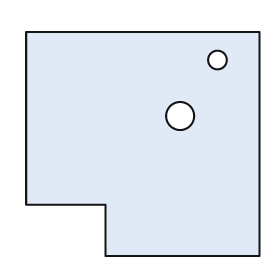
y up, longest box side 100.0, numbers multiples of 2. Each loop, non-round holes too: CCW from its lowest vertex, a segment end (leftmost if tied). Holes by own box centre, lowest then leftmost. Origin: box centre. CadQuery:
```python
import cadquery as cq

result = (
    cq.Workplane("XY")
    .moveTo(-16.0, -48.0)
    .lineTo(50.0, -48.0)
    .lineTo(50.0, 48.0)
    .lineTo(-50.0, 48.0)
    .lineTo(-50.0, -26.0)
    .lineTo(-16.0, -26.0)
    .close()
    .moveTo(16.0, 12.0)
    .circle(6.0)
    .moveTo(32.0, 36.0)
    .circle(4.0)
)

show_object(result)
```